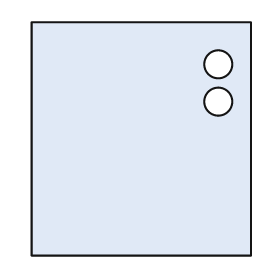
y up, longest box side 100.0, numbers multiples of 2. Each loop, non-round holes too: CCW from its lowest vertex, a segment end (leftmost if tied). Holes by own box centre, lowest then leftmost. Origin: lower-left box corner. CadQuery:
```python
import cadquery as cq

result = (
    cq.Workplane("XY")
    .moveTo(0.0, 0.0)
    .lineTo(94.0, 0.0)
    .lineTo(94.0, 100.0)
    .lineTo(0.0, 100.0)
    .close()
    .moveTo(80.0, 66.0)
    .circle(6.0)
    .moveTo(80.0, 82.0)
    .circle(6.0)
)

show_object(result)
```